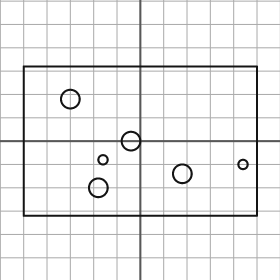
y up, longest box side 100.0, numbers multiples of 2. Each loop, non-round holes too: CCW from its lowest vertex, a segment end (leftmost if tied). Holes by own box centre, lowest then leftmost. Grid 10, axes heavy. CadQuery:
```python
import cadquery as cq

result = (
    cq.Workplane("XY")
    .moveTo(-50.0, -32.0)
    .lineTo(50.0, -32.0)
    .lineTo(50.0, 32.0)
    .lineTo(-50.0, 32.0)
    .close()
    .moveTo(-18.0, -20.0)
    .circle(4.0)
    .moveTo(18.0, -14.0)
    .circle(4.0)
    .moveTo(44.0, -10.0)
    .circle(2.0)
    .moveTo(-16.0, -8.0)
    .circle(2.0)
    .moveTo(-4.0, 0.0)
    .circle(4.0)
    .moveTo(-30.0, 18.0)
    .circle(4.0)
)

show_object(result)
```